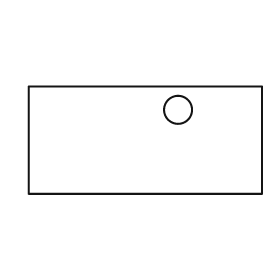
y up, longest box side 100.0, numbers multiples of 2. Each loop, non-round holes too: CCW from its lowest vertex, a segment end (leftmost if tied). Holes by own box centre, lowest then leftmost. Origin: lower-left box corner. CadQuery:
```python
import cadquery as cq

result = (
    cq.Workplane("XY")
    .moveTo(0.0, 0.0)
    .lineTo(100.0, 0.0)
    .lineTo(100.0, 46.0)
    .lineTo(0.0, 46.0)
    .close()
    .moveTo(64.0, 36.0)
    .circle(6.0)
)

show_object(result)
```